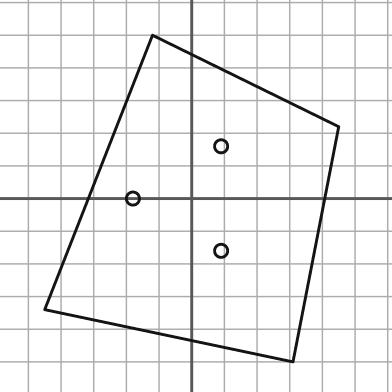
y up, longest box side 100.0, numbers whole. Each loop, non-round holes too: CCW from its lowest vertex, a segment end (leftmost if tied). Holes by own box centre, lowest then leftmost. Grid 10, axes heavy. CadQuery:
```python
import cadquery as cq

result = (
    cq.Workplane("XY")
    .moveTo(31.0, -50.0)
    .lineTo(45.0, 22.0)
    .lineTo(-12.0, 50.0)
    .lineTo(-45.0, -34.0)
    .close()
    .moveTo(9.0, -16.0)
    .circle(2.0)
    .moveTo(-18.0, 0.0)
    .circle(2.0)
    .moveTo(9.0, 16.0)
    .circle(2.0)
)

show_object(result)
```